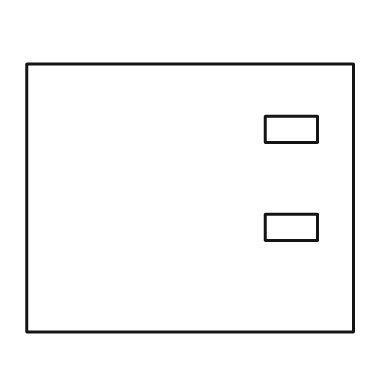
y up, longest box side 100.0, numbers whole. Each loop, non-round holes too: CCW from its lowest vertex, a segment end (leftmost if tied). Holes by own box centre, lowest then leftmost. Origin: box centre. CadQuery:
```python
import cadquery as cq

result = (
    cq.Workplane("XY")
    .moveTo(-50.0, -41.0)
    .lineTo(50.0, -41.0)
    .lineTo(50.0, 41.0)
    .lineTo(-50.0, 41.0)
    .close()
    .moveTo(23.0, -13.0)
    .lineTo(39.0, -13.0)
    .lineTo(39.0, -5.0)
    .lineTo(23.0, -5.0)
    .close()
    .moveTo(23.0, 17.0)
    .lineTo(39.0, 17.0)
    .lineTo(39.0, 25.0)
    .lineTo(23.0, 25.0)
    .close()
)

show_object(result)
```